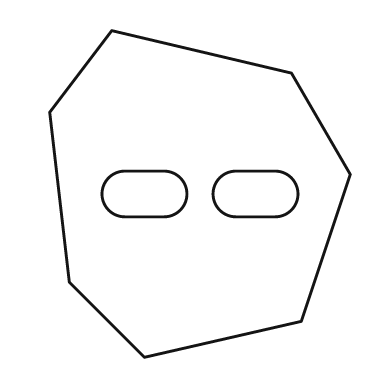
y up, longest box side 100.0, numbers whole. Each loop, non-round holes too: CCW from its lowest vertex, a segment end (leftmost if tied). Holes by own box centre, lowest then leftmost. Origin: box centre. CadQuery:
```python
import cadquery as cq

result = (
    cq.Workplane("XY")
    .moveTo(-17.0, -50.0)
    .lineTo(31.0, -39.0)
    .lineTo(46.0, 6.0)
    .lineTo(28.0, 37.0)
    .lineTo(-27.0, 50.0)
    .lineTo(-46.0, 25.0)
    .lineTo(-40.0, -27.0)
    .close()
    .moveTo(-23.0, -7.0)
    .lineTo(-11.0, -7.0)
    .threePointArc((-4.0, 0.0), (-11.0, 7.0))
    .lineTo(-23.0, 7.0)
    .threePointArc((-30.0, 0.0), (-23.0, -7.0))
    .close()
    .moveTo(11.0, -7.0)
    .lineTo(23.0, -7.0)
    .threePointArc((30.0, 0.0), (23.0, 7.0))
    .lineTo(11.0, 7.0)
    .threePointArc((4.0, 0.0), (11.0, -7.0))
    .close()
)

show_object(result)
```